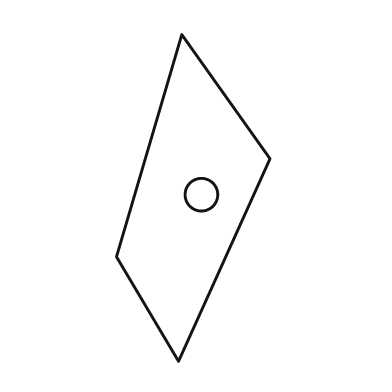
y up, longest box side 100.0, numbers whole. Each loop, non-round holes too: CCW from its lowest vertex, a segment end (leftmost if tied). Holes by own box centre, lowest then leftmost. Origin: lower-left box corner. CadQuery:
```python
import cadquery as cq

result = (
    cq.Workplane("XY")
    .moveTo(19.0, 0.0)
    .lineTo(47.0, 62.0)
    .lineTo(20.0, 100.0)
    .lineTo(0.0, 32.0)
    .close()
    .moveTo(26.0, 51.0)
    .circle(5.0)
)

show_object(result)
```